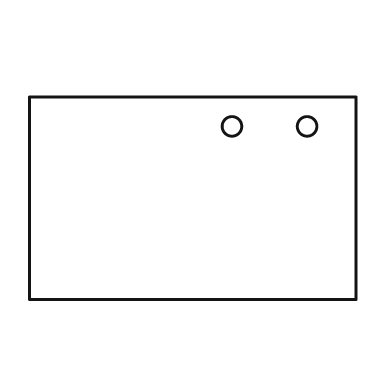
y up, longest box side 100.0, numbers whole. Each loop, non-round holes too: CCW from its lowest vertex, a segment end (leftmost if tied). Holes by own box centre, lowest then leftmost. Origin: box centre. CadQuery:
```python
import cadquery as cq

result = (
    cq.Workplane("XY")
    .moveTo(-50.0, -31.0)
    .lineTo(50.0, -31.0)
    .lineTo(50.0, 31.0)
    .lineTo(-50.0, 31.0)
    .close()
    .moveTo(12.0, 22.0)
    .circle(3.0)
    .moveTo(35.0, 22.0)
    .circle(3.0)
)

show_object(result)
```